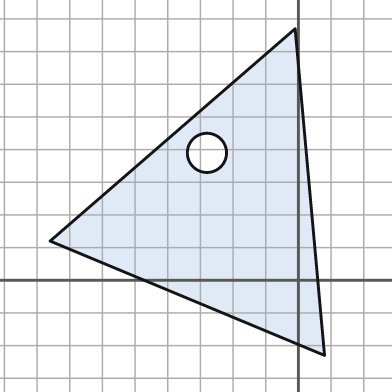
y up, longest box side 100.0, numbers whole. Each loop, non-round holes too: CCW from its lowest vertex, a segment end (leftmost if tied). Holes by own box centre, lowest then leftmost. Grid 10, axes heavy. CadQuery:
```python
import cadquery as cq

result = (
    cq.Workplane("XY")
    .moveTo(8.0, -23.0)
    .lineTo(-1.0, 77.0)
    .lineTo(-76.0, 12.0)
    .close()
    .moveTo(-28.0, 39.0)
    .circle(6.0)
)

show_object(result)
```